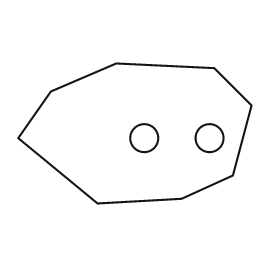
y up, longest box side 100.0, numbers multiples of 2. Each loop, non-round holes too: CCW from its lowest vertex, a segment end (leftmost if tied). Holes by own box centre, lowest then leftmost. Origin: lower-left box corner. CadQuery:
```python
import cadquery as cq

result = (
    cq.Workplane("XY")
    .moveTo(34.0, 0.0)
    .lineTo(70.0, 2.0)
    .lineTo(92.0, 12.0)
    .lineTo(100.0, 42.0)
    .lineTo(84.0, 58.0)
    .lineTo(42.0, 60.0)
    .lineTo(14.0, 48.0)
    .lineTo(0.0, 28.0)
    .close()
    .moveTo(54.0, 28.0)
    .circle(6.0)
    .moveTo(82.0, 28.0)
    .circle(6.0)
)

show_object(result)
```